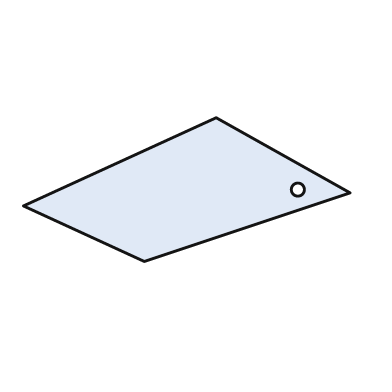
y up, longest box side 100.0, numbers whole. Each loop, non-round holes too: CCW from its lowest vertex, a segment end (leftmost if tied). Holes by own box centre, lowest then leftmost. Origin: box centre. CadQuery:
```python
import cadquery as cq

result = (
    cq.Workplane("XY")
    .moveTo(-13.0, -22.0)
    .lineTo(50.0, -1.0)
    .lineTo(9.0, 22.0)
    .lineTo(-50.0, -5.0)
    .close()
    .moveTo(34.0, 0.0)
    .circle(2.0)
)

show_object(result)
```